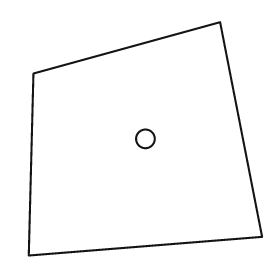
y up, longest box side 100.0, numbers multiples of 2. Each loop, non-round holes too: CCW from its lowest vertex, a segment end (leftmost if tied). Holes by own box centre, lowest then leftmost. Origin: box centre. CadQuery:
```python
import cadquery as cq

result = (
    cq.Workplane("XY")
    .moveTo(-50.0, -50.0)
    .lineTo(50.0, -42.0)
    .lineTo(32.0, 50.0)
    .lineTo(-48.0, 28.0)
    .close()
    .moveTo(0.0, 0.0)
    .circle(4.0)
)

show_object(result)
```